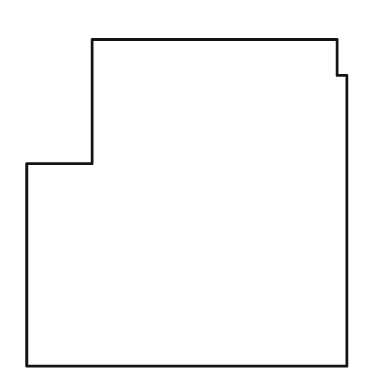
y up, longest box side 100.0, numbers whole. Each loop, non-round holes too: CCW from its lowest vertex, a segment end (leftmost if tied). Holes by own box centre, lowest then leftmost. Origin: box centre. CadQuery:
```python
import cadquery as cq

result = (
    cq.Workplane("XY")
    .moveTo(-49.0, -50.0)
    .lineTo(49.0, -50.0)
    .lineTo(49.0, 39.0)
    .lineTo(46.0, 39.0)
    .lineTo(46.0, 50.0)
    .lineTo(-29.0, 50.0)
    .lineTo(-29.0, 12.0)
    .lineTo(-49.0, 12.0)
    .close()
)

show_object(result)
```